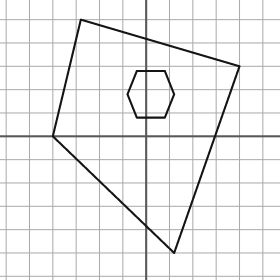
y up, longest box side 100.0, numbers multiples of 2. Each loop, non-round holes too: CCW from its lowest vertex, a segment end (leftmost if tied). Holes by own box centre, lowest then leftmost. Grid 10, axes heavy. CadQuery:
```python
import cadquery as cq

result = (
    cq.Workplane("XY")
    .moveTo(12.0, -50.0)
    .lineTo(40.0, 30.0)
    .lineTo(-28.0, 50.0)
    .lineTo(-40.0, 0.0)
    .close()
    .moveTo(-4.0, 8.0)
    .lineTo(8.0, 8.0)
    .lineTo(12.0, 18.0)
    .lineTo(8.0, 28.0)
    .lineTo(-4.0, 28.0)
    .lineTo(-8.0, 18.0)
    .close()
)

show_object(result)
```